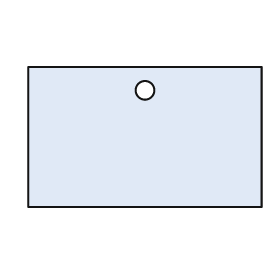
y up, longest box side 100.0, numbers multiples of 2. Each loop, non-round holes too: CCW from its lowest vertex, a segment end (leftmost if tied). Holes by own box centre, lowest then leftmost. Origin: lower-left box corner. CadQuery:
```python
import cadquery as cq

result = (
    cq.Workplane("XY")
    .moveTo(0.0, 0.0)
    .lineTo(100.0, 0.0)
    .lineTo(100.0, 60.0)
    .lineTo(0.0, 60.0)
    .close()
    .moveTo(50.0, 50.0)
    .circle(4.0)
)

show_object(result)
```